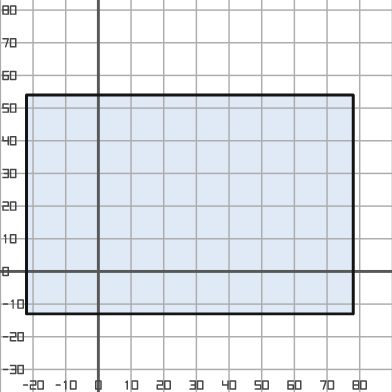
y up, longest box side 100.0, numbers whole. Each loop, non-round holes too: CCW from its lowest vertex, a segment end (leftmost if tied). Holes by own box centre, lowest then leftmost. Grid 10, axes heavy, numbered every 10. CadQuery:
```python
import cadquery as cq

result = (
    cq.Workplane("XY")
    .moveTo(-22.0, -13.0)
    .lineTo(78.0, -13.0)
    .lineTo(78.0, 54.0)
    .lineTo(-22.0, 54.0)
    .close()
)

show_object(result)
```